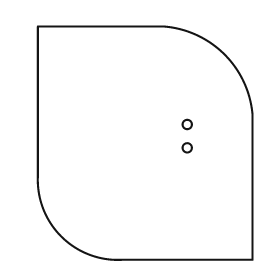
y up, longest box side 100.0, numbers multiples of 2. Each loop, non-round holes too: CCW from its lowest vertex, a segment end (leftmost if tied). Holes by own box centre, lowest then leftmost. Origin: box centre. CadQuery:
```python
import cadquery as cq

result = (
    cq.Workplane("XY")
    .moveTo(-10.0, -50.0)
    .lineTo(46.0, -50.0)
    .lineTo(46.0, 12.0)
    .threePointArc((34.0, 38.0), (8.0, 50.0))
    .lineTo(-46.0, 50.0)
    .lineTo(-46.0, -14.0)
    .threePointArc((-36.0, -40.0), (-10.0, -50.0))
    .close()
    .moveTo(18.0, -2.0)
    .circle(2.0)
    .moveTo(18.0, 8.0)
    .circle(2.0)
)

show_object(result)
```